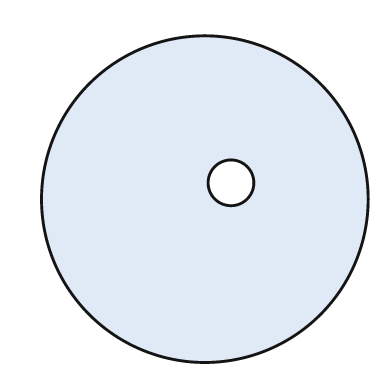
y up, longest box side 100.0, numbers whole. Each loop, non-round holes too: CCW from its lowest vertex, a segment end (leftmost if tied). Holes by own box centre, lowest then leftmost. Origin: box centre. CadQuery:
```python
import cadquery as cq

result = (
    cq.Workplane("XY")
    .moveTo(0.0, 0.0)
    .circle(50.0)
    .moveTo(8.0, 5.0)
    .circle(7.0)
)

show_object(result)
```